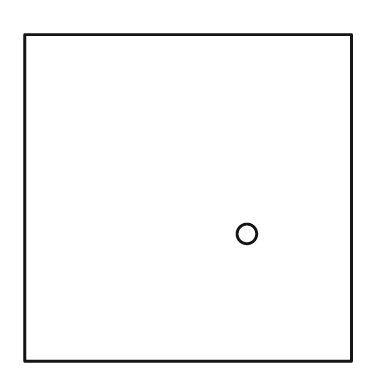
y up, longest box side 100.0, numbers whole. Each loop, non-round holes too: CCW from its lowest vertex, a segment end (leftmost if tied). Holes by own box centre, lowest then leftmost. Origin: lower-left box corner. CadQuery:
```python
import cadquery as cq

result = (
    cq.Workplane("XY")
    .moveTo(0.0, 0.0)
    .lineTo(100.0, 0.0)
    .lineTo(100.0, 100.0)
    .lineTo(0.0, 100.0)
    .close()
    .moveTo(68.0, 39.0)
    .circle(3.0)
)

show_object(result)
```